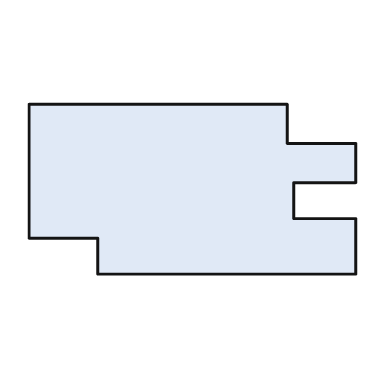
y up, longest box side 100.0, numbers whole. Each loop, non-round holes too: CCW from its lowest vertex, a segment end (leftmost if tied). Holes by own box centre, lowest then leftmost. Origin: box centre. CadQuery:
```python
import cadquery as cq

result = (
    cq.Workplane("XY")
    .moveTo(-29.0, -26.0)
    .lineTo(50.0, -26.0)
    .lineTo(50.0, -9.0)
    .lineTo(31.0, -9.0)
    .lineTo(31.0, 2.0)
    .lineTo(50.0, 2.0)
    .lineTo(50.0, 14.0)
    .lineTo(29.0, 14.0)
    .lineTo(29.0, 26.0)
    .lineTo(-50.0, 26.0)
    .lineTo(-50.0, -15.0)
    .lineTo(-29.0, -15.0)
    .close()
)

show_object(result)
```